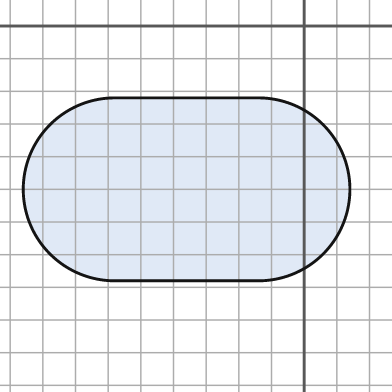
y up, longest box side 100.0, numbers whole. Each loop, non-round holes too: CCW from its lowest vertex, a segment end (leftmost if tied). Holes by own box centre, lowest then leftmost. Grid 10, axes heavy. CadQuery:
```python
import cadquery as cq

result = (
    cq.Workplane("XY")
    .moveTo(-58.0, -78.0)
    .lineTo(-14.0, -78.0)
    .threePointArc((14.0, -50.0), (-14.0, -22.0))
    .lineTo(-58.0, -22.0)
    .threePointArc((-86.0, -50.0), (-58.0, -78.0))
    .close()
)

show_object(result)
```